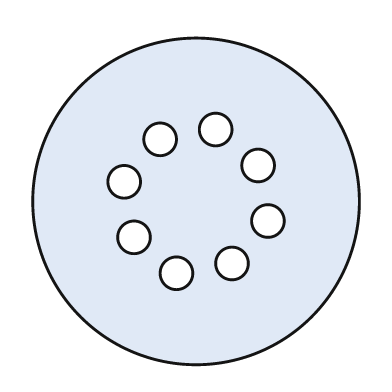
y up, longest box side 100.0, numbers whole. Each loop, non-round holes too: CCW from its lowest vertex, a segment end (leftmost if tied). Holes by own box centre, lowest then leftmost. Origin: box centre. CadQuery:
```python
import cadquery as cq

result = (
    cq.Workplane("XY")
    .moveTo(0.0, 0.0)
    .circle(50.0)
    .moveTo(-6.0, -22.0)
    .circle(5.0)
    .moveTo(11.0, -19.0)
    .circle(5.0)
    .moveTo(-19.0, -11.0)
    .circle(5.0)
    .moveTo(22.0, -6.0)
    .circle(5.0)
    .moveTo(-22.0, 6.0)
    .circle(5.0)
    .moveTo(19.0, 11.0)
    .circle(5.0)
    .moveTo(-11.0, 19.0)
    .circle(5.0)
    .moveTo(6.0, 22.0)
    .circle(5.0)
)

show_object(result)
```